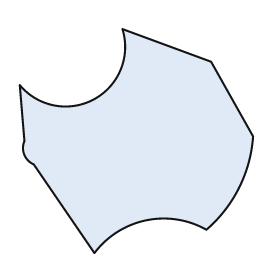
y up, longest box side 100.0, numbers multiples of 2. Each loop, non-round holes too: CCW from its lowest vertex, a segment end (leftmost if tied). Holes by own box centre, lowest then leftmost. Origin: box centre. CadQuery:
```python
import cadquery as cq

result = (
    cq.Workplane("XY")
    .moveTo(-18.0, -48.0)
    .threePointArc((4.0, -34.0), (30.0, -38.0))
    .threePointArc((44.0, -20.0), (50.0, 2.0))
    .lineTo(32.0, 34.0)
    .lineTo(-6.0, 48.0)
    .threePointArc((-18.0, 18.0), (-50.0, 24.0))
    .lineTo(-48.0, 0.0)
    .threePointArc((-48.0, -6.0), (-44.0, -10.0))
    .close()
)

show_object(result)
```